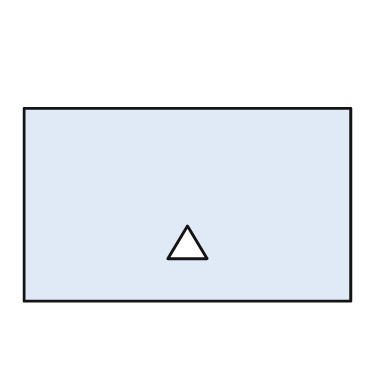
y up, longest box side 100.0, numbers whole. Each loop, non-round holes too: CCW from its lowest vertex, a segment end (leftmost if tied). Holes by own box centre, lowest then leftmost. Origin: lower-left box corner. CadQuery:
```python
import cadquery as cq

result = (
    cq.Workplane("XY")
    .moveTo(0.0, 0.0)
    .lineTo(100.0, 0.0)
    .lineTo(100.0, 59.0)
    .lineTo(0.0, 59.0)
    .close()
    .moveTo(44.0, 13.0)
    .lineTo(56.0, 13.0)
    .lineTo(50.0, 23.0)
    .close()
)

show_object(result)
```